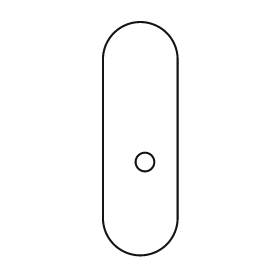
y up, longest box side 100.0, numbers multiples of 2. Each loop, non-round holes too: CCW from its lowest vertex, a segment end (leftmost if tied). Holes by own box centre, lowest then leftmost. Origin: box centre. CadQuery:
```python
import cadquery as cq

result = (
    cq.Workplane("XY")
    .moveTo(-16.0, -34.0)
    .threePointArc((0.0, -50.0), (16.0, -34.0))
    .lineTo(16.0, 34.0)
    .threePointArc((0.0, 50.0), (-16.0, 34.0))
    .close()
    .moveTo(2.0, -10.0)
    .circle(4.0)
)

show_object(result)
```